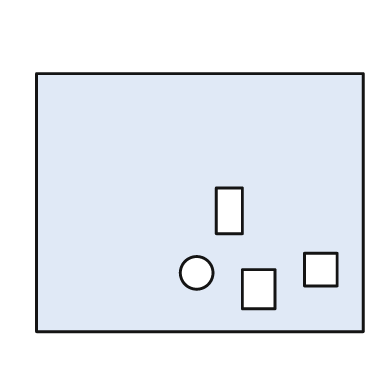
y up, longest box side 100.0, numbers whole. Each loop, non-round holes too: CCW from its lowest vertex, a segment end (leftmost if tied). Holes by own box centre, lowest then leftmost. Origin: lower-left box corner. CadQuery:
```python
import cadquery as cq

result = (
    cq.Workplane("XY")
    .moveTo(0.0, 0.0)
    .lineTo(100.0, 0.0)
    .lineTo(100.0, 79.0)
    .lineTo(0.0, 79.0)
    .close()
    .moveTo(63.0, 7.0)
    .lineTo(73.0, 7.0)
    .lineTo(73.0, 19.0)
    .lineTo(63.0, 19.0)
    .close()
    .moveTo(49.0, 18.0)
    .circle(5.0)
    .moveTo(82.0, 14.0)
    .lineTo(92.0, 14.0)
    .lineTo(92.0, 24.0)
    .lineTo(82.0, 24.0)
    .close()
    .moveTo(55.0, 30.0)
    .lineTo(63.0, 30.0)
    .lineTo(63.0, 44.0)
    .lineTo(55.0, 44.0)
    .close()
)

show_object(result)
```